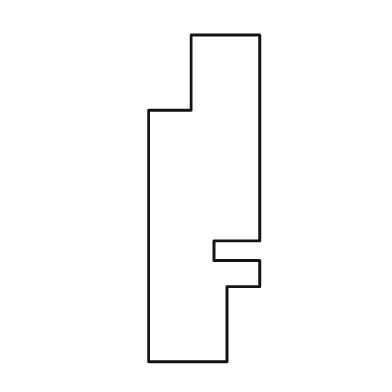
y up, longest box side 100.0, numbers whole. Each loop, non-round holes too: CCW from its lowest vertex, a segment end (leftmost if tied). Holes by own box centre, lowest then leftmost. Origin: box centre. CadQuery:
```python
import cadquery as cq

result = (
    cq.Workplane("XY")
    .moveTo(-17.0, -50.0)
    .lineTo(7.0, -50.0)
    .lineTo(7.0, -27.0)
    .lineTo(17.0, -27.0)
    .lineTo(17.0, -19.0)
    .lineTo(3.0, -19.0)
    .lineTo(3.0, -13.0)
    .lineTo(17.0, -13.0)
    .lineTo(17.0, 50.0)
    .lineTo(-4.0, 50.0)
    .lineTo(-4.0, 27.0)
    .lineTo(-17.0, 27.0)
    .close()
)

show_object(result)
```